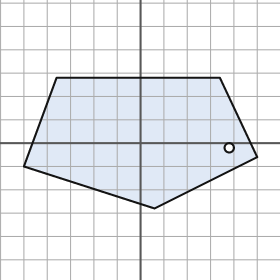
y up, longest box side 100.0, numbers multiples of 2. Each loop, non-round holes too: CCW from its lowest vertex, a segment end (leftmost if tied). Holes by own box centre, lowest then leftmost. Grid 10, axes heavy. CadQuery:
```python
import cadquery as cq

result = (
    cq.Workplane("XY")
    .moveTo(6.0, -28.0)
    .lineTo(50.0, -6.0)
    .lineTo(34.0, 28.0)
    .lineTo(-36.0, 28.0)
    .lineTo(-50.0, -10.0)
    .close()
    .moveTo(38.0, -2.0)
    .circle(2.0)
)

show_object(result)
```